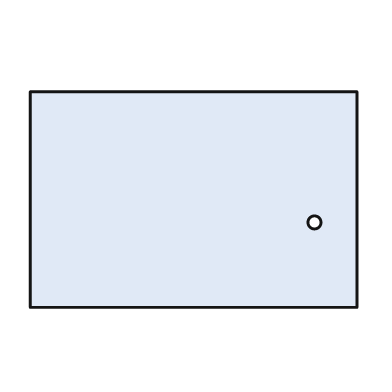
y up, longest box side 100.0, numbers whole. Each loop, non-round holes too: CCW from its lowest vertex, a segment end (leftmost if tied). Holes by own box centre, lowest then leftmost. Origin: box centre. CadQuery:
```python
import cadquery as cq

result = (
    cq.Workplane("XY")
    .moveTo(-50.0, -33.0)
    .lineTo(50.0, -33.0)
    .lineTo(50.0, 33.0)
    .lineTo(-50.0, 33.0)
    .close()
    .moveTo(37.0, -7.0)
    .circle(2.0)
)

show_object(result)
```